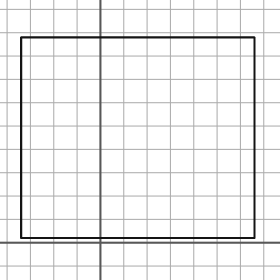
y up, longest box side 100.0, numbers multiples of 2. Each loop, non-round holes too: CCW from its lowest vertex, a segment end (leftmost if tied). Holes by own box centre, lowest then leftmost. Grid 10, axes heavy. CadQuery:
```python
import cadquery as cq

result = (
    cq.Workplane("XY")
    .moveTo(-34.0, 2.0)
    .lineTo(66.0, 2.0)
    .lineTo(66.0, 88.0)
    .lineTo(-34.0, 88.0)
    .close()
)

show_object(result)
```